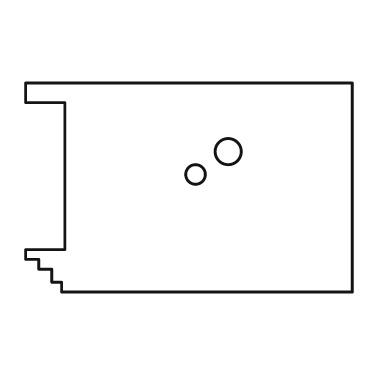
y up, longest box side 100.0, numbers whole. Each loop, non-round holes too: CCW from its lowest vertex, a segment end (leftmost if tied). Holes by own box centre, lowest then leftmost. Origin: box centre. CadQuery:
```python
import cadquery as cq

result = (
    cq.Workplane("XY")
    .moveTo(-39.0, -32.0)
    .lineTo(50.0, -32.0)
    .lineTo(50.0, 32.0)
    .lineTo(-50.0, 32.0)
    .lineTo(-50.0, 26.0)
    .lineTo(-38.0, 26.0)
    .lineTo(-38.0, -19.0)
    .lineTo(-50.0, -19.0)
    .lineTo(-50.0, -22.0)
    .lineTo(-46.0, -22.0)
    .lineTo(-46.0, -25.0)
    .lineTo(-42.0, -25.0)
    .lineTo(-42.0, -29.0)
    .lineTo(-39.0, -29.0)
    .close()
    .moveTo(2.0, 4.0)
    .circle(3.0)
    .moveTo(12.0, 11.0)
    .circle(4.0)
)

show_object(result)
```